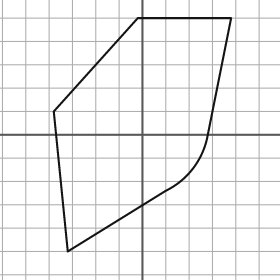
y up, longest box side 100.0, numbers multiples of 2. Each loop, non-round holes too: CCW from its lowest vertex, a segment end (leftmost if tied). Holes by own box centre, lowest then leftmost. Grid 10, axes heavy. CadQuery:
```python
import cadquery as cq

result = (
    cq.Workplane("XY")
    .moveTo(-32.0, -50.0)
    .lineTo(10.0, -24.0)
    .threePointArc((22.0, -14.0), (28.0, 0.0))
    .lineTo(38.0, 50.0)
    .lineTo(-2.0, 50.0)
    .lineTo(-38.0, 10.0)
    .close()
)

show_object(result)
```